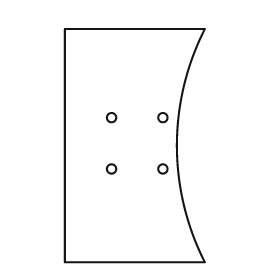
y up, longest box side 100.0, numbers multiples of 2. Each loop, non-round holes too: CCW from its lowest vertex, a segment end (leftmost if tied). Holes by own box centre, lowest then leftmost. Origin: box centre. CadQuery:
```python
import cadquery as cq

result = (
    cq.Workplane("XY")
    .moveTo(-30.0, -50.0)
    .lineTo(30.0, -50.0)
    .threePointArc((18.0, 0.0), (30.0, 50.0))
    .lineTo(-30.0, 50.0)
    .close()
    .moveTo(-10.0, -10.0)
    .circle(2.0)
    .moveTo(12.0, -10.0)
    .circle(2.0)
    .moveTo(-10.0, 12.0)
    .circle(2.0)
    .moveTo(12.0, 12.0)
    .circle(2.0)
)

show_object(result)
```